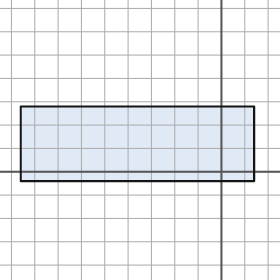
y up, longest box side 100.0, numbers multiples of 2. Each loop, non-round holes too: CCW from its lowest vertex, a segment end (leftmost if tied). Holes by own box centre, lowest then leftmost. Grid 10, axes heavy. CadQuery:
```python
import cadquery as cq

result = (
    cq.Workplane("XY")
    .moveTo(-86.0, -4.0)
    .lineTo(14.0, -4.0)
    .lineTo(14.0, 28.0)
    .lineTo(-86.0, 28.0)
    .close()
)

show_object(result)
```